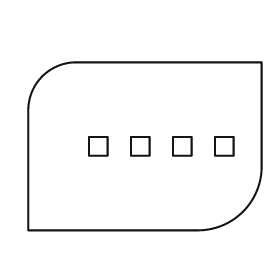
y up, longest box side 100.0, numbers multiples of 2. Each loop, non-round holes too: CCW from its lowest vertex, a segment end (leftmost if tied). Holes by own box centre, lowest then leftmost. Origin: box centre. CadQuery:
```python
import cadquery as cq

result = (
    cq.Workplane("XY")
    .moveTo(-50.0, -36.0)
    .lineTo(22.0, -36.0)
    .threePointArc((42.0, -28.0), (50.0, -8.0))
    .lineTo(50.0, 36.0)
    .lineTo(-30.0, 36.0)
    .threePointArc((-44.0, 30.0), (-50.0, 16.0))
    .close()
    .moveTo(-24.0, -4.0)
    .lineTo(-16.0, -4.0)
    .lineTo(-16.0, 4.0)
    .lineTo(-24.0, 4.0)
    .close()
    .moveTo(-6.0, -4.0)
    .lineTo(2.0, -4.0)
    .lineTo(2.0, 4.0)
    .lineTo(-6.0, 4.0)
    .close()
    .moveTo(12.0, -4.0)
    .lineTo(20.0, -4.0)
    .lineTo(20.0, 4.0)
    .lineTo(12.0, 4.0)
    .close()
    .moveTo(30.0, -4.0)
    .lineTo(38.0, -4.0)
    .lineTo(38.0, 4.0)
    .lineTo(30.0, 4.0)
    .close()
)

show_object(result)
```